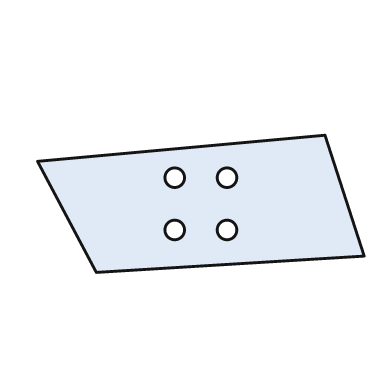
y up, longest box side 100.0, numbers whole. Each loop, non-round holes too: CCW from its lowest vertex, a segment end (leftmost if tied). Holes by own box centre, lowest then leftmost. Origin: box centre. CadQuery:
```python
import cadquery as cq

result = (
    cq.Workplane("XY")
    .moveTo(-32.0, -21.0)
    .lineTo(50.0, -16.0)
    .lineTo(38.0, 21.0)
    .lineTo(-50.0, 13.0)
    .close()
    .moveTo(-8.0, -8.0)
    .circle(3.0)
    .moveTo(8.0, -8.0)
    .circle(3.0)
    .moveTo(-8.0, 8.0)
    .circle(3.0)
    .moveTo(8.0, 8.0)
    .circle(3.0)
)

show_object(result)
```